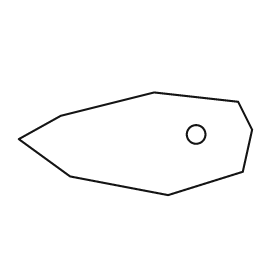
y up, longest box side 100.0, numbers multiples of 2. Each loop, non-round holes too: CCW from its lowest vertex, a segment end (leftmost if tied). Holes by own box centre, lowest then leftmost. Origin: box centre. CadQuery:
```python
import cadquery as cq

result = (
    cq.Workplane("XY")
    .moveTo(14.0, -22.0)
    .lineTo(46.0, -12.0)
    .lineTo(50.0, 6.0)
    .lineTo(44.0, 18.0)
    .lineTo(8.0, 22.0)
    .lineTo(-32.0, 12.0)
    .lineTo(-50.0, 2.0)
    .lineTo(-28.0, -14.0)
    .close()
    .moveTo(26.0, 4.0)
    .circle(4.0)
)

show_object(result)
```